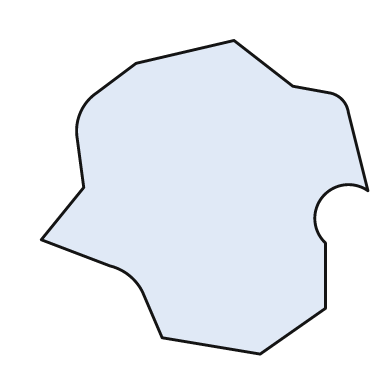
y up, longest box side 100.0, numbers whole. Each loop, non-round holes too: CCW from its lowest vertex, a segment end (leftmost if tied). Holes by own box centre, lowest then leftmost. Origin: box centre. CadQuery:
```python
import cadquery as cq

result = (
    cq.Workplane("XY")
    .moveTo(17.0, -48.0)
    .lineTo(37.0, -34.0)
    .lineTo(37.0, -14.0)
    .threePointArc((36.0, 0.0), (50.0, 2.0))
    .lineTo(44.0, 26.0)
    .threePointArc((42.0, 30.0), (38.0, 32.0))
    .lineTo(27.0, 34.0)
    .lineTo(9.0, 48.0)
    .lineTo(-21.0, 41.0)
    .lineTo(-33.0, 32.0)
    .threePointArc((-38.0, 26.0), (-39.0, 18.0))
    .lineTo(-37.0, 3.0)
    .lineTo(-50.0, -13.0)
    .lineTo(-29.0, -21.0)
    .threePointArc((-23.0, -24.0), (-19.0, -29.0))
    .lineTo(-13.0, -43.0)
    .close()
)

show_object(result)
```